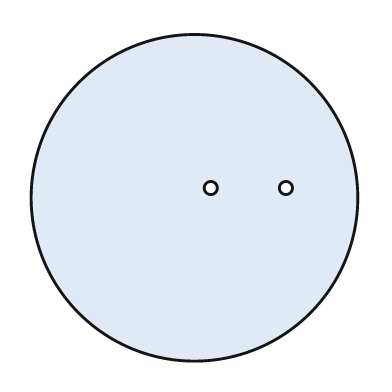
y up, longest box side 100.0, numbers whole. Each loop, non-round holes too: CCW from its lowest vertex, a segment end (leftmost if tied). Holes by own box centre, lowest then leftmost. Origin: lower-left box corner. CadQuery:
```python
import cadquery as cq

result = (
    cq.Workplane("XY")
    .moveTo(50.0, 50.0)
    .circle(50.0)
    .moveTo(55.0, 53.0)
    .circle(2.0)
    .moveTo(78.0, 53.0)
    .circle(2.0)
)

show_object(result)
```